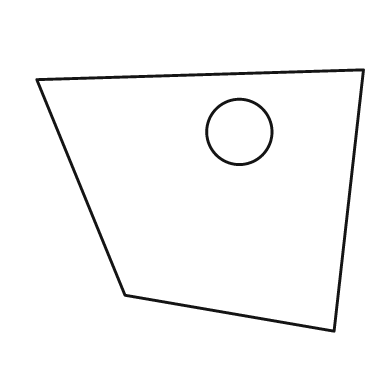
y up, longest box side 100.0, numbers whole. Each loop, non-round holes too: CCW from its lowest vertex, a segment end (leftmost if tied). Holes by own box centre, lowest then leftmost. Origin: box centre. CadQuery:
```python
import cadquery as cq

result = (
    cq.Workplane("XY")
    .moveTo(41.0, -40.0)
    .lineTo(50.0, 40.0)
    .lineTo(-50.0, 37.0)
    .lineTo(-23.0, -29.0)
    .close()
    .moveTo(12.0, 21.0)
    .circle(10.0)
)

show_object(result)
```